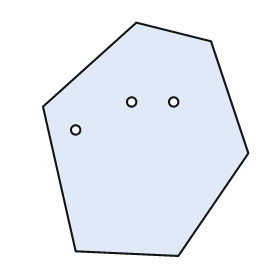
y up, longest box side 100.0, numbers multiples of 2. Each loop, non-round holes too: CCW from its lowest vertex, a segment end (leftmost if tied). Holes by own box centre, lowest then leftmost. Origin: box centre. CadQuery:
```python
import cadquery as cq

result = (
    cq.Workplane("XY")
    .moveTo(14.0, -50.0)
    .lineTo(44.0, -6.0)
    .lineTo(28.0, 42.0)
    .lineTo(-4.0, 50.0)
    .lineTo(-44.0, 14.0)
    .lineTo(-30.0, -48.0)
    .close()
    .moveTo(-30.0, 4.0)
    .circle(2.0)
    .moveTo(-6.0, 16.0)
    .circle(2.0)
    .moveTo(12.0, 16.0)
    .circle(2.0)
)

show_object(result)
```